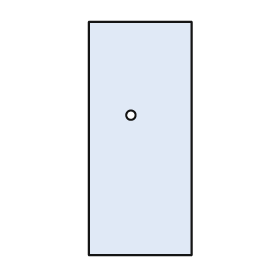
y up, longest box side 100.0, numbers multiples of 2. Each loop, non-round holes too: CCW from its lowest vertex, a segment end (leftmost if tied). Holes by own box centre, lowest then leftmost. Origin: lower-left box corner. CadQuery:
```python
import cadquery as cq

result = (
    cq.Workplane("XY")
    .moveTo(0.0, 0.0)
    .lineTo(44.0, 0.0)
    .lineTo(44.0, 100.0)
    .lineTo(0.0, 100.0)
    .close()
    .moveTo(18.0, 60.0)
    .circle(2.0)
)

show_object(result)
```